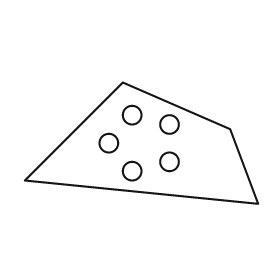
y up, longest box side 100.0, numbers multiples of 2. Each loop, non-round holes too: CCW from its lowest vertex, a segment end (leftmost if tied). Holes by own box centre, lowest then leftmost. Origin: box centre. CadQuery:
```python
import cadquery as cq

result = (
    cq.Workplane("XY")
    .moveTo(50.0, -26.0)
    .lineTo(38.0, 6.0)
    .lineTo(-8.0, 26.0)
    .lineTo(-50.0, -16.0)
    .close()
    .moveTo(-4.0, -12.0)
    .circle(4.0)
    .moveTo(12.0, -8.0)
    .circle(4.0)
    .moveTo(-14.0, 0.0)
    .circle(4.0)
    .moveTo(12.0, 8.0)
    .circle(4.0)
    .moveTo(-4.0, 12.0)
    .circle(4.0)
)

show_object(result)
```